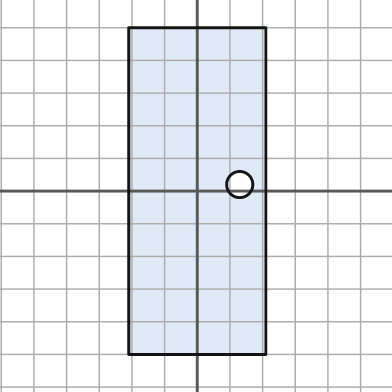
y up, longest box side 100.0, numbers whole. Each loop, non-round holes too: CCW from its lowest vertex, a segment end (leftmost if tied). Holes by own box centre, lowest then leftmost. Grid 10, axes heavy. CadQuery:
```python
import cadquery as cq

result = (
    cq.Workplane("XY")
    .moveTo(-21.0, -50.0)
    .lineTo(21.0, -50.0)
    .lineTo(21.0, 50.0)
    .lineTo(-21.0, 50.0)
    .close()
    .moveTo(13.0, 2.0)
    .circle(4.0)
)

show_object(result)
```